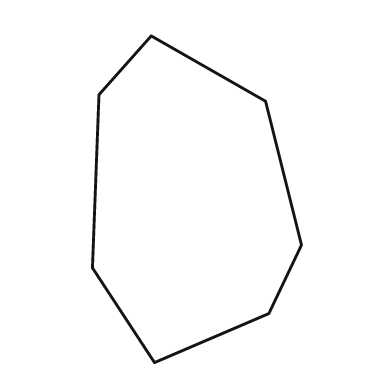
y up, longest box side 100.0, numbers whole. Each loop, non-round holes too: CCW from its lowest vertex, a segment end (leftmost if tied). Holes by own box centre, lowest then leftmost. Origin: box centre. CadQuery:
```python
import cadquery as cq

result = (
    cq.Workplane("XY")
    .moveTo(-13.0, -50.0)
    .lineTo(22.0, -35.0)
    .lineTo(32.0, -14.0)
    .lineTo(21.0, 30.0)
    .lineTo(-14.0, 50.0)
    .lineTo(-30.0, 32.0)
    .lineTo(-32.0, -21.0)
    .close()
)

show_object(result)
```